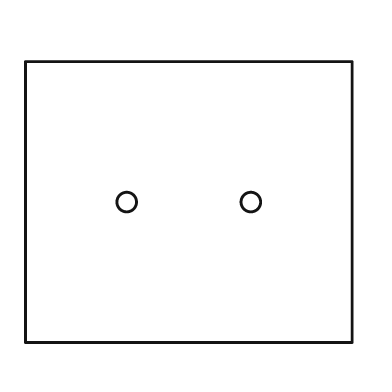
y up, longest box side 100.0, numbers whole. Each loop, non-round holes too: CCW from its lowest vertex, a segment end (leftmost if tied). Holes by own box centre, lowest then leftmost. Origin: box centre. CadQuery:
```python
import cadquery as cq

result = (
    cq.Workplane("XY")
    .moveTo(-50.0, -43.0)
    .lineTo(50.0, -43.0)
    .lineTo(50.0, 43.0)
    .lineTo(-50.0, 43.0)
    .close()
    .moveTo(-19.0, 0.0)
    .circle(3.0)
    .moveTo(19.0, 0.0)
    .circle(3.0)
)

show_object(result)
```